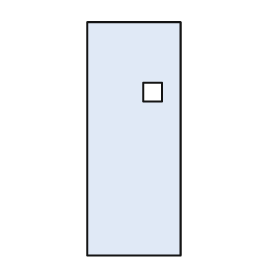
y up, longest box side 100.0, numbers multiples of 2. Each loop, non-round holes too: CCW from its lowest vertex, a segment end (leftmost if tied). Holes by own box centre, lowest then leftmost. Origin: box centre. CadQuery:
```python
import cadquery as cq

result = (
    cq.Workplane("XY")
    .moveTo(-20.0, -50.0)
    .lineTo(20.0, -50.0)
    .lineTo(20.0, 50.0)
    .lineTo(-20.0, 50.0)
    .close()
    .moveTo(4.0, 16.0)
    .lineTo(12.0, 16.0)
    .lineTo(12.0, 24.0)
    .lineTo(4.0, 24.0)
    .close()
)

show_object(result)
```